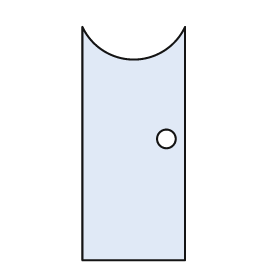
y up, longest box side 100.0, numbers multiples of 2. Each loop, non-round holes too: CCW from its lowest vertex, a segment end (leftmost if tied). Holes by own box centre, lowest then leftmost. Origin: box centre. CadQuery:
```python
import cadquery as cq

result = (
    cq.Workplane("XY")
    .moveTo(-22.0, -50.0)
    .lineTo(22.0, -50.0)
    .lineTo(22.0, 50.0)
    .threePointArc((0.0, 36.0), (-22.0, 50.0))
    .close()
    .moveTo(14.0, 2.0)
    .circle(4.0)
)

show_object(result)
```